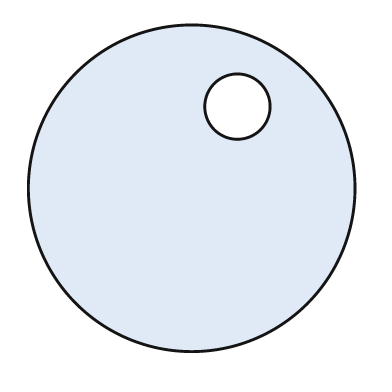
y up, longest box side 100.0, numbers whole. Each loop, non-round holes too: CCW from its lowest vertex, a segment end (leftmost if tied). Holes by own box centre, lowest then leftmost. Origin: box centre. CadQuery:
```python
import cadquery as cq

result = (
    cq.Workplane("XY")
    .moveTo(0.0, 0.0)
    .circle(50.0)
    .moveTo(14.0, 25.0)
    .circle(10.0)
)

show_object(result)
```